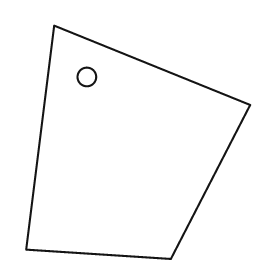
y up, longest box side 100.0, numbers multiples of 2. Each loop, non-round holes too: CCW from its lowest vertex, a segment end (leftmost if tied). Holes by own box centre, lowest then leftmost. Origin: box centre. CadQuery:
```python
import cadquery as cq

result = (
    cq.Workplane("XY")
    .moveTo(14.0, -50.0)
    .lineTo(48.0, 16.0)
    .lineTo(-36.0, 50.0)
    .lineTo(-48.0, -46.0)
    .close()
    .moveTo(-22.0, 28.0)
    .circle(4.0)
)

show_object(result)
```